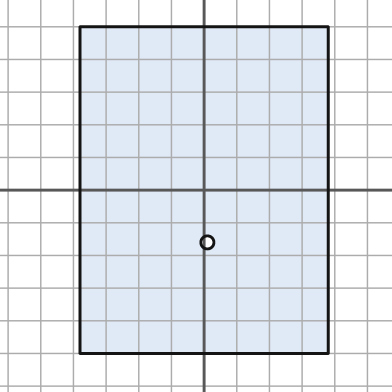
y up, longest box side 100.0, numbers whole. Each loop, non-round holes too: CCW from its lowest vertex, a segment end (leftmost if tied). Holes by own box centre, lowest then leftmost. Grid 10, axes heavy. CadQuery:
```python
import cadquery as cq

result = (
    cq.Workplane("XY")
    .moveTo(-38.0, -50.0)
    .lineTo(38.0, -50.0)
    .lineTo(38.0, 50.0)
    .lineTo(-38.0, 50.0)
    .close()
    .moveTo(1.0, -16.0)
    .circle(2.0)
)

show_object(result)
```